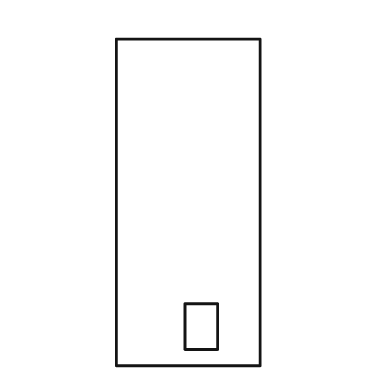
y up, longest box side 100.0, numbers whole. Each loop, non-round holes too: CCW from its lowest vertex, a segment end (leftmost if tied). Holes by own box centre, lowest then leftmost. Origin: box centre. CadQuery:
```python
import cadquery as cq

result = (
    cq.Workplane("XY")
    .moveTo(-22.0, -50.0)
    .lineTo(22.0, -50.0)
    .lineTo(22.0, 50.0)
    .lineTo(-22.0, 50.0)
    .close()
    .moveTo(-1.0, -45.0)
    .lineTo(9.0, -45.0)
    .lineTo(9.0, -31.0)
    .lineTo(-1.0, -31.0)
    .close()
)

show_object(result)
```